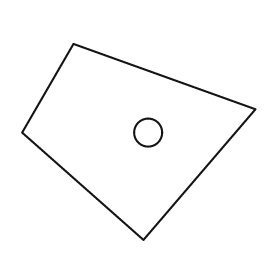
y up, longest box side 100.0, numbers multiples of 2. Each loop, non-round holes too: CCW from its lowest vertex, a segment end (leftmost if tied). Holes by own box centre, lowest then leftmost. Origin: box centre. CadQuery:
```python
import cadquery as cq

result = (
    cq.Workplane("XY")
    .moveTo(2.0, -42.0)
    .lineTo(50.0, 14.0)
    .lineTo(-28.0, 42.0)
    .lineTo(-50.0, 4.0)
    .close()
    .moveTo(4.0, 4.0)
    .circle(6.0)
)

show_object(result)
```